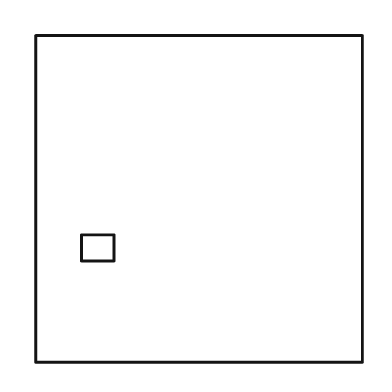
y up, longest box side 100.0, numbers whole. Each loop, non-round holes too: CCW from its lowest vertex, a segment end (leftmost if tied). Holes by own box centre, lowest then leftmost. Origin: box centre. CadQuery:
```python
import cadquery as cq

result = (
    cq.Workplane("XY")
    .moveTo(-50.0, -50.0)
    .lineTo(50.0, -50.0)
    .lineTo(50.0, 50.0)
    .lineTo(-50.0, 50.0)
    .close()
    .moveTo(-36.0, -19.0)
    .lineTo(-26.0, -19.0)
    .lineTo(-26.0, -11.0)
    .lineTo(-36.0, -11.0)
    .close()
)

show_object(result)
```